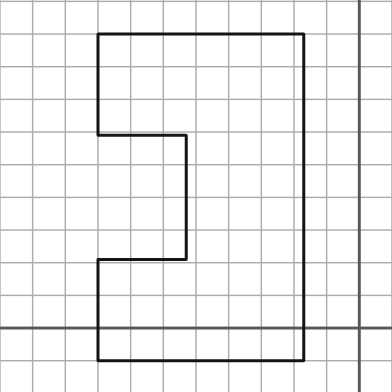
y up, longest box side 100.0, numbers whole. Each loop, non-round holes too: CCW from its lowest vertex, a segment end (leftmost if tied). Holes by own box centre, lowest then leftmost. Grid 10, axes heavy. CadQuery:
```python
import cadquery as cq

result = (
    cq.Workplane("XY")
    .moveTo(-80.0, -10.0)
    .lineTo(-17.0, -10.0)
    .lineTo(-17.0, 90.0)
    .lineTo(-80.0, 90.0)
    .lineTo(-80.0, 59.0)
    .lineTo(-53.0, 59.0)
    .lineTo(-53.0, 21.0)
    .lineTo(-80.0, 21.0)
    .close()
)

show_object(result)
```